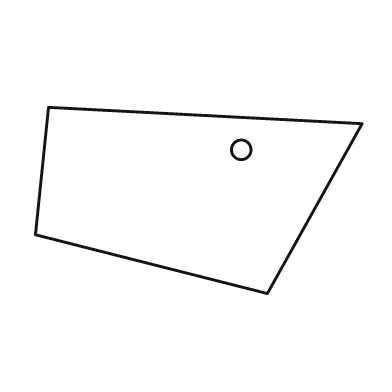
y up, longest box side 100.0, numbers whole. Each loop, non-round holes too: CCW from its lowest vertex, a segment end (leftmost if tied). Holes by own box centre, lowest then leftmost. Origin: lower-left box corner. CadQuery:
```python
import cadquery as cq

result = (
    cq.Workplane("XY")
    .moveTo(71.0, 0.0)
    .lineTo(100.0, 52.0)
    .lineTo(4.0, 57.0)
    .lineTo(0.0, 18.0)
    .close()
    .moveTo(63.0, 44.0)
    .circle(3.0)
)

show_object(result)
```